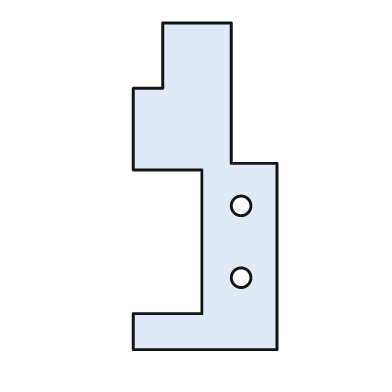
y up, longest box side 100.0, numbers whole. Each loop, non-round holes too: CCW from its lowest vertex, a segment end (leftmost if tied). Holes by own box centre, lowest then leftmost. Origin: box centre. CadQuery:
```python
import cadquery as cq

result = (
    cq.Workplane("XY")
    .moveTo(-22.0, -50.0)
    .lineTo(22.0, -50.0)
    .lineTo(22.0, 7.0)
    .lineTo(8.0, 7.0)
    .lineTo(8.0, 50.0)
    .lineTo(-13.0, 50.0)
    .lineTo(-13.0, 30.0)
    .lineTo(-22.0, 30.0)
    .lineTo(-22.0, 5.0)
    .lineTo(-1.0, 5.0)
    .lineTo(-1.0, -39.0)
    .lineTo(-22.0, -39.0)
    .close()
    .moveTo(11.0, -28.0)
    .circle(3.0)
    .moveTo(11.0, -6.0)
    .circle(3.0)
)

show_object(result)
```